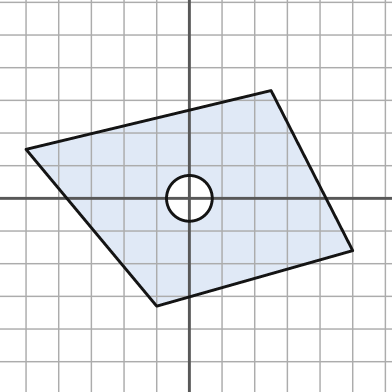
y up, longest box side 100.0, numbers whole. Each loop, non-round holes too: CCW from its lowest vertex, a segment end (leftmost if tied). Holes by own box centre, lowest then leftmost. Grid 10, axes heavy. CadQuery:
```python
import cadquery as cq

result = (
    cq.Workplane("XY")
    .moveTo(-10.0, -33.0)
    .lineTo(50.0, -16.0)
    .lineTo(25.0, 33.0)
    .lineTo(-50.0, 15.0)
    .close()
    .moveTo(0.0, 0.0)
    .circle(7.0)
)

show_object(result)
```